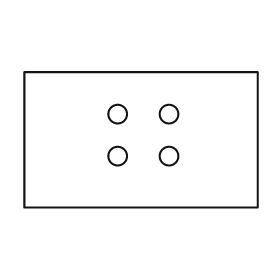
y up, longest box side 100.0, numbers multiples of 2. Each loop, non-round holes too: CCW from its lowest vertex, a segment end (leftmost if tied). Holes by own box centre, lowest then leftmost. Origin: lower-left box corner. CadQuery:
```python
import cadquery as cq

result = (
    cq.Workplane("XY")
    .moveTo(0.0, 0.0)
    .lineTo(100.0, 0.0)
    .lineTo(100.0, 58.0)
    .lineTo(0.0, 58.0)
    .close()
    .moveTo(40.0, 22.0)
    .circle(4.0)
    .moveTo(62.0, 22.0)
    .circle(4.0)
    .moveTo(40.0, 40.0)
    .circle(4.0)
    .moveTo(62.0, 40.0)
    .circle(4.0)
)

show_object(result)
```